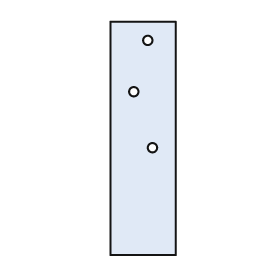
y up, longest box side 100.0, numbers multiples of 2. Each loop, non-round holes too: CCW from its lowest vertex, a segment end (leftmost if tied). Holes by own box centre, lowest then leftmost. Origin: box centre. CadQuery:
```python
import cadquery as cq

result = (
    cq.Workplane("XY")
    .moveTo(-14.0, -50.0)
    .lineTo(14.0, -50.0)
    .lineTo(14.0, 50.0)
    .lineTo(-14.0, 50.0)
    .close()
    .moveTo(4.0, -4.0)
    .circle(2.0)
    .moveTo(-4.0, 20.0)
    .circle(2.0)
    .moveTo(2.0, 42.0)
    .circle(2.0)
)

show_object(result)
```